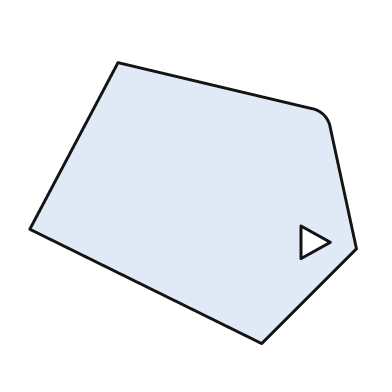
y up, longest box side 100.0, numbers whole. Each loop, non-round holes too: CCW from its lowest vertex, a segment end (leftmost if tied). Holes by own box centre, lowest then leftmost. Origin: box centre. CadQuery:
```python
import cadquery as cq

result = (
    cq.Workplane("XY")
    .moveTo(21.0, -43.0)
    .lineTo(50.0, -14.0)
    .lineTo(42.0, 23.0)
    .threePointArc((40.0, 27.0), (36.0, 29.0))
    .lineTo(-23.0, 43.0)
    .lineTo(-50.0, -8.0)
    .close()
    .moveTo(33.0, -17.0)
    .lineTo(42.0, -12.0)
    .lineTo(33.0, -7.0)
    .close()
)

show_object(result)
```